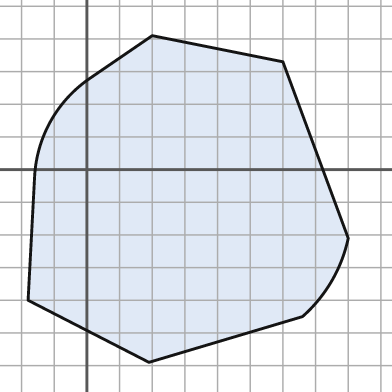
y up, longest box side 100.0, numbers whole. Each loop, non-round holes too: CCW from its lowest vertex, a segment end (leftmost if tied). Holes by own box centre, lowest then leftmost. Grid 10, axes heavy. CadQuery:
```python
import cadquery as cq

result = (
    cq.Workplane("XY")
    .moveTo(19.0, -59.0)
    .lineTo(66.0, -45.0)
    .threePointArc((75.0, -34.0), (80.0, -21.0))
    .lineTo(60.0, 33.0)
    .lineTo(20.0, 41.0)
    .lineTo(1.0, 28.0)
    .threePointArc((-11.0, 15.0), (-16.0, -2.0))
    .lineTo(-18.0, -40.0)
    .close()
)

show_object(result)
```